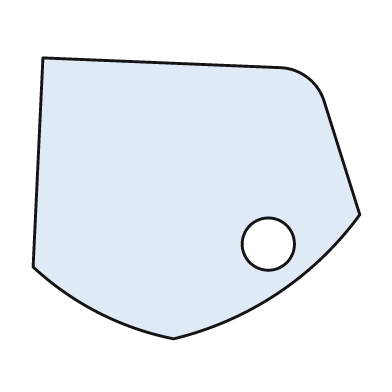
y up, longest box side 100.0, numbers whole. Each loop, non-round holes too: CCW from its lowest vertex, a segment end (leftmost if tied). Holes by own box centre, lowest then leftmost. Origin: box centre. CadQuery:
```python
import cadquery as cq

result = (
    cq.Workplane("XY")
    .moveTo(-7.0, -43.0)
    .threePointArc((25.0, -29.0), (50.0, -5.0))
    .lineTo(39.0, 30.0)
    .threePointArc((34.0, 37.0), (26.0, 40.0))
    .lineTo(-47.0, 43.0)
    .lineTo(-50.0, -21.0)
    .threePointArc((-30.0, -35.0), (-7.0, -43.0))
    .close()
    .moveTo(22.0, -14.0)
    .circle(8.0)
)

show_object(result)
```